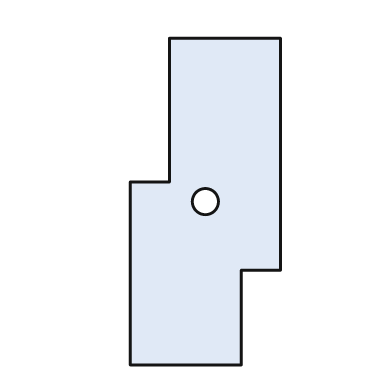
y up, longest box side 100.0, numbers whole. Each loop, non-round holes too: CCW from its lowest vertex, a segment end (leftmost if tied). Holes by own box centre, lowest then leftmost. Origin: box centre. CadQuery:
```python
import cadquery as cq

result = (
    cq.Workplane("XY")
    .moveTo(-23.0, -50.0)
    .lineTo(11.0, -50.0)
    .lineTo(11.0, -21.0)
    .lineTo(23.0, -21.0)
    .lineTo(23.0, 50.0)
    .lineTo(-11.0, 50.0)
    .lineTo(-11.0, 6.0)
    .lineTo(-23.0, 6.0)
    .close()
    .moveTo(0.0, 0.0)
    .circle(4.0)
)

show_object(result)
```